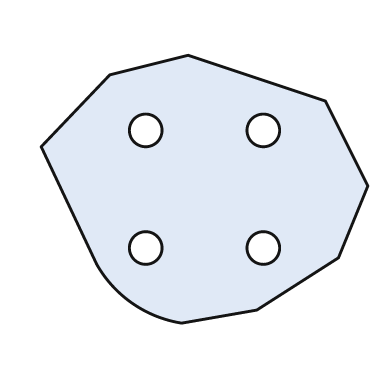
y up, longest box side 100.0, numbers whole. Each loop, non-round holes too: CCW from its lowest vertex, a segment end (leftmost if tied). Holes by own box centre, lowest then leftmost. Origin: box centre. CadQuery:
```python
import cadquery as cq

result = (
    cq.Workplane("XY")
    .moveTo(-7.0, -41.0)
    .lineTo(16.0, -37.0)
    .lineTo(41.0, -21.0)
    .lineTo(50.0, 1.0)
    .lineTo(37.0, 27.0)
    .lineTo(-5.0, 41.0)
    .lineTo(-29.0, 35.0)
    .lineTo(-50.0, 13.0)
    .lineTo(-33.0, -23.0)
    .threePointArc((-22.0, -35.0), (-7.0, -41.0))
    .close()
    .moveTo(-18.0, -18.0)
    .circle(5.0)
    .moveTo(18.0, -18.0)
    .circle(5.0)
    .moveTo(-18.0, 18.0)
    .circle(5.0)
    .moveTo(18.0, 18.0)
    .circle(5.0)
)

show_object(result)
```